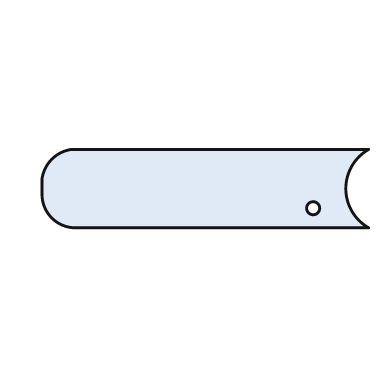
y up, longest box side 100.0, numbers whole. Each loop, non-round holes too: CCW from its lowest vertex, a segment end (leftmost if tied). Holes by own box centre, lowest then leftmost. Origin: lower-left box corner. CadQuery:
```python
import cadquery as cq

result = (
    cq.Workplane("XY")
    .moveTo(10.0, 0.0)
    .lineTo(100.0, 0.0)
    .threePointArc((93.0, 12.0), (100.0, 24.0))
    .lineTo(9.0, 24.0)
    .threePointArc((3.0, 21.0), (0.0, 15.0))
    .lineTo(0.0, 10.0)
    .threePointArc((3.0, 3.0), (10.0, 0.0))
    .close()
    .moveTo(83.0, 6.0)
    .circle(2.0)
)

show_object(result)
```